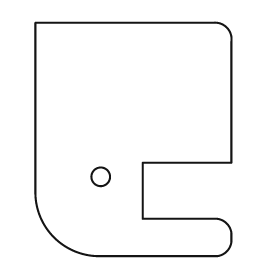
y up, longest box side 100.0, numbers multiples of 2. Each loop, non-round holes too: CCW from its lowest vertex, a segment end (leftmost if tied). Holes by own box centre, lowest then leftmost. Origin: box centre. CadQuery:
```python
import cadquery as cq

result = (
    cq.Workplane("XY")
    .moveTo(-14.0, -50.0)
    .lineTo(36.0, -50.0)
    .threePointArc((40.0, -48.0), (42.0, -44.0))
    .lineTo(42.0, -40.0)
    .threePointArc((40.0, -36.0), (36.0, -34.0))
    .lineTo(4.0, -34.0)
    .lineTo(4.0, -10.0)
    .lineTo(42.0, -10.0)
    .lineTo(42.0, 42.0)
    .threePointArc((40.0, 48.0), (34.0, 50.0))
    .lineTo(-42.0, 50.0)
    .lineTo(-42.0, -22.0)
    .threePointArc((-34.0, -42.0), (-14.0, -50.0))
    .close()
    .moveTo(-14.0, -16.0)
    .circle(4.0)
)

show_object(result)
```